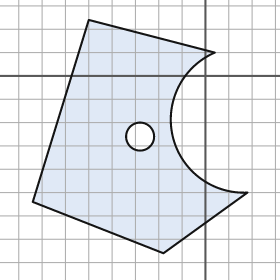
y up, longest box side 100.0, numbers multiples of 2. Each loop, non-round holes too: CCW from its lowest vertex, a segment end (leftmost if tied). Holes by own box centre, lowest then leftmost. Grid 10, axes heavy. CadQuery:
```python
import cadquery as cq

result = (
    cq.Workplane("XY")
    .moveTo(-18.0, -76.0)
    .lineTo(18.0, -50.0)
    .threePointArc((-14.0, -26.0), (4.0, 10.0))
    .lineTo(-50.0, 24.0)
    .lineTo(-74.0, -54.0)
    .close()
    .moveTo(-28.0, -26.0)
    .circle(6.0)
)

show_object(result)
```